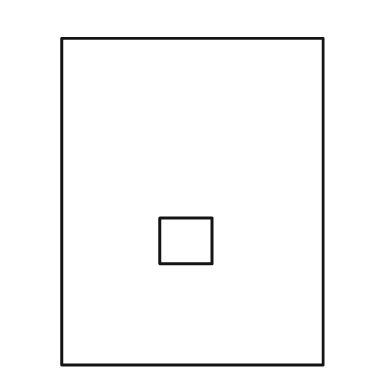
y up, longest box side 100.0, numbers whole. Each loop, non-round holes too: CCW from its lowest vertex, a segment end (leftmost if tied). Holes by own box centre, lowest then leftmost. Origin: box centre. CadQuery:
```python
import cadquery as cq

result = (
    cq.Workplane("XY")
    .moveTo(-40.0, -50.0)
    .lineTo(40.0, -50.0)
    .lineTo(40.0, 50.0)
    .lineTo(-40.0, 50.0)
    .close()
    .moveTo(-10.0, -19.0)
    .lineTo(6.0, -19.0)
    .lineTo(6.0, -5.0)
    .lineTo(-10.0, -5.0)
    .close()
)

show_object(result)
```